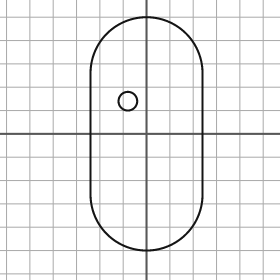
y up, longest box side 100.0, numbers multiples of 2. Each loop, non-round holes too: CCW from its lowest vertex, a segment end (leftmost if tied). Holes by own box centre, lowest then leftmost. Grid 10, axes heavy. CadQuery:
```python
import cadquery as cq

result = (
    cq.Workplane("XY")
    .moveTo(-24.0, -26.0)
    .threePointArc((0.0, -50.0), (24.0, -26.0))
    .lineTo(24.0, 26.0)
    .threePointArc((0.0, 50.0), (-24.0, 26.0))
    .close()
    .moveTo(-8.0, 14.0)
    .circle(4.0)
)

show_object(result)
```